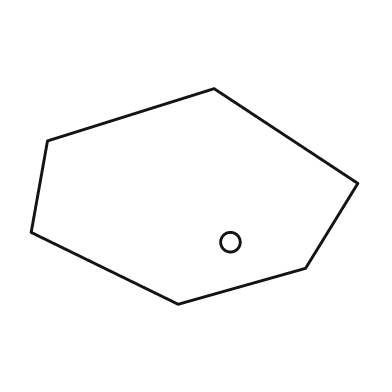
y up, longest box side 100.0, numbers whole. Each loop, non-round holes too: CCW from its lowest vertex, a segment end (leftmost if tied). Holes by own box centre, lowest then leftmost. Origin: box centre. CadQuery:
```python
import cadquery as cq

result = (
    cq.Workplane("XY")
    .moveTo(-5.0, -33.0)
    .lineTo(34.0, -22.0)
    .lineTo(50.0, 4.0)
    .lineTo(6.0, 33.0)
    .lineTo(-45.0, 17.0)
    .lineTo(-50.0, -11.0)
    .close()
    .moveTo(11.0, -14.0)
    .circle(3.0)
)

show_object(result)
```